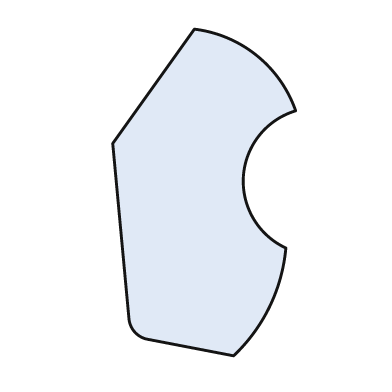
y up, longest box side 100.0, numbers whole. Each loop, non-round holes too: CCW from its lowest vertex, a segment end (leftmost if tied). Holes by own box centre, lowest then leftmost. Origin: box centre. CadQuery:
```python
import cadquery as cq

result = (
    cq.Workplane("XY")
    .moveTo(9.0, -50.0)
    .threePointArc((20.0, -35.0), (25.0, -17.0))
    .threePointArc((12.0, 5.0), (28.0, 25.0))
    .threePointArc((16.0, 42.0), (-3.0, 50.0))
    .lineTo(-28.0, 15.0)
    .lineTo(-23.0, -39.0)
    .threePointArc((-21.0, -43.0), (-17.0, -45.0))
    .close()
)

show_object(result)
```